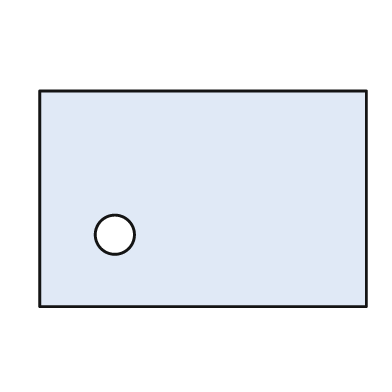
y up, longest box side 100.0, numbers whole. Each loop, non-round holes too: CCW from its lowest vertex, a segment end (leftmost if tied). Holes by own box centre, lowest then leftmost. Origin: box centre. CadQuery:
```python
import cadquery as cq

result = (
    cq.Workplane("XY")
    .moveTo(-50.0, -33.0)
    .lineTo(50.0, -33.0)
    .lineTo(50.0, 33.0)
    .lineTo(-50.0, 33.0)
    .close()
    .moveTo(-27.0, -11.0)
    .circle(6.0)
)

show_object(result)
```